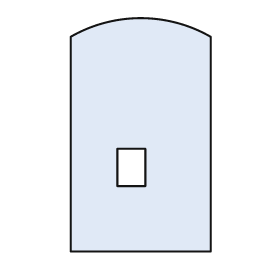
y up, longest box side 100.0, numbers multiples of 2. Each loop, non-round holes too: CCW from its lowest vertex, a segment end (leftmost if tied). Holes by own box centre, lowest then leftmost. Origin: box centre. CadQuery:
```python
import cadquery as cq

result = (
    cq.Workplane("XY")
    .moveTo(-30.0, -50.0)
    .lineTo(30.0, -50.0)
    .lineTo(30.0, 42.0)
    .threePointArc((0.0, 50.0), (-30.0, 42.0))
    .close()
    .moveTo(-10.0, -22.0)
    .lineTo(2.0, -22.0)
    .lineTo(2.0, -6.0)
    .lineTo(-10.0, -6.0)
    .close()
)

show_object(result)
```